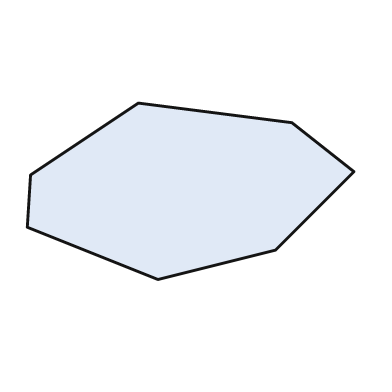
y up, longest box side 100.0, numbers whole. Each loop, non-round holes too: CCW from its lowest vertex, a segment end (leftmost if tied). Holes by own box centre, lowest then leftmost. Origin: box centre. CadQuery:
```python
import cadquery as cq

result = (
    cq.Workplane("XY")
    .moveTo(-10.0, -27.0)
    .lineTo(26.0, -18.0)
    .lineTo(50.0, 6.0)
    .lineTo(31.0, 21.0)
    .lineTo(-16.0, 27.0)
    .lineTo(-49.0, 5.0)
    .lineTo(-50.0, -11.0)
    .close()
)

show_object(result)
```